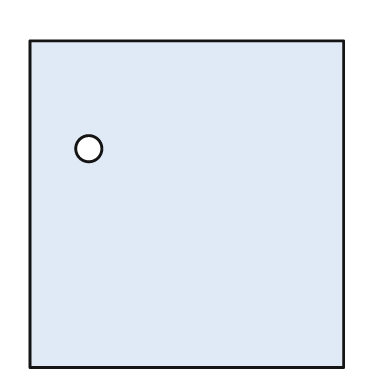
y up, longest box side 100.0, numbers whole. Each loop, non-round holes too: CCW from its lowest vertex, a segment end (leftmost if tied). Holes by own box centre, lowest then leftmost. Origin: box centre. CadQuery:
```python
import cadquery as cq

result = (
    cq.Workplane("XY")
    .moveTo(-48.0, -50.0)
    .lineTo(48.0, -50.0)
    .lineTo(48.0, 50.0)
    .lineTo(-48.0, 50.0)
    .close()
    .moveTo(-30.0, 17.0)
    .circle(4.0)
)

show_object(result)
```